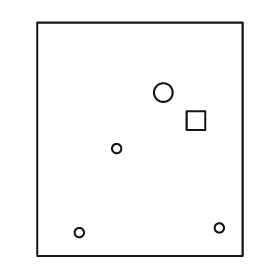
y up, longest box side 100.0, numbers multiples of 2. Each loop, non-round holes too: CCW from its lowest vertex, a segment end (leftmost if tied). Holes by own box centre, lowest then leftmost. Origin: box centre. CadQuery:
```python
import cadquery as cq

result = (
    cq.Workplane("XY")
    .moveTo(-44.0, -50.0)
    .lineTo(44.0, -50.0)
    .lineTo(44.0, 50.0)
    .lineTo(-44.0, 50.0)
    .close()
    .moveTo(-26.0, -40.0)
    .circle(2.0)
    .moveTo(34.0, -38.0)
    .circle(2.0)
    .moveTo(-10.0, -4.0)
    .circle(2.0)
    .moveTo(20.0, 4.0)
    .lineTo(28.0, 4.0)
    .lineTo(28.0, 12.0)
    .lineTo(20.0, 12.0)
    .close()
    .moveTo(10.0, 20.0)
    .circle(4.0)
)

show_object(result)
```